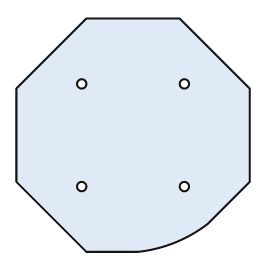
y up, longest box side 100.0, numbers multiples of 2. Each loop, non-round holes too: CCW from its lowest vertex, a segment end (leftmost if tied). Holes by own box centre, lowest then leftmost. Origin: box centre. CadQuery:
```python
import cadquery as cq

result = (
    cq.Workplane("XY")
    .moveTo(-20.0, -50.0)
    .lineTo(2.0, -50.0)
    .threePointArc((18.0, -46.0), (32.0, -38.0))
    .lineTo(50.0, -20.0)
    .lineTo(50.0, 20.0)
    .lineTo(20.0, 50.0)
    .lineTo(-20.0, 50.0)
    .lineTo(-50.0, 20.0)
    .lineTo(-50.0, -20.0)
    .close()
    .moveTo(-22.0, -22.0)
    .circle(2.0)
    .moveTo(22.0, -22.0)
    .circle(2.0)
    .moveTo(-22.0, 22.0)
    .circle(2.0)
    .moveTo(22.0, 22.0)
    .circle(2.0)
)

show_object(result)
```